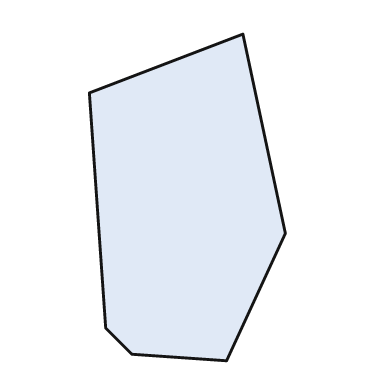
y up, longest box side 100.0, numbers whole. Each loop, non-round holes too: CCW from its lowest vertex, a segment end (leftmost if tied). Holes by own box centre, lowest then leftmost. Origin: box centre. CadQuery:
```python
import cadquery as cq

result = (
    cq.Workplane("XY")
    .moveTo(12.0, -50.0)
    .lineTo(30.0, -11.0)
    .lineTo(17.0, 50.0)
    .lineTo(-30.0, 32.0)
    .lineTo(-25.0, -40.0)
    .lineTo(-17.0, -48.0)
    .close()
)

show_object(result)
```